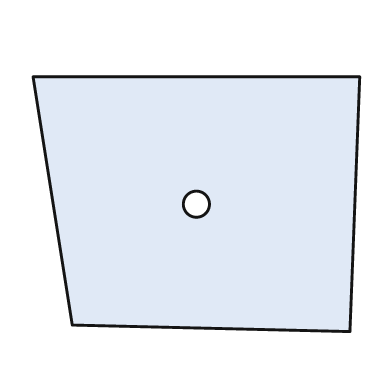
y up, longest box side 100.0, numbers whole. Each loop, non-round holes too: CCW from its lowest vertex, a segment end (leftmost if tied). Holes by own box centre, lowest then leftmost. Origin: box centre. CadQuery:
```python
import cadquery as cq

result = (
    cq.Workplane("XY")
    .moveTo(47.0, -39.0)
    .lineTo(50.0, 39.0)
    .lineTo(-50.0, 39.0)
    .lineTo(-38.0, -37.0)
    .close()
    .moveTo(0.0, 0.0)
    .circle(4.0)
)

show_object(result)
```